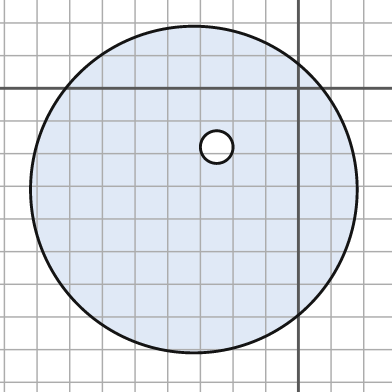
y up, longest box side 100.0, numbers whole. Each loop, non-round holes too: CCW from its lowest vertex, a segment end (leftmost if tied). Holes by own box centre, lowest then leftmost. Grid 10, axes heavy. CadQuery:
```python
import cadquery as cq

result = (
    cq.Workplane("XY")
    .moveTo(-32.0, -31.0)
    .circle(50.0)
    .moveTo(-25.0, -18.0)
    .circle(5.0)
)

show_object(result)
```